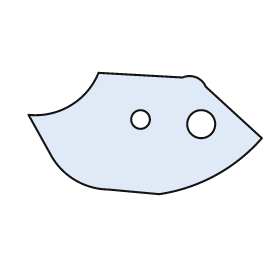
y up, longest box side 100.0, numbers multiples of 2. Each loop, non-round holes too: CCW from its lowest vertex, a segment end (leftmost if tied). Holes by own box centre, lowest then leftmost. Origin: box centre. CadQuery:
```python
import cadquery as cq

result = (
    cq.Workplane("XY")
    .moveTo(6.0, -26.0)
    .threePointArc((30.0, -18.0), (50.0, -2.0))
    .lineTo(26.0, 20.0)
    .threePointArc((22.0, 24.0), (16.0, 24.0))
    .lineTo(-20.0, 26.0)
    .threePointArc((-32.0, 12.0), (-50.0, 8.0))
    .lineTo(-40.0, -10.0)
    .threePointArc((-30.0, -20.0), (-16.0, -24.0))
    .close()
    .moveTo(24.0, 4.0)
    .circle(6.0)
    .moveTo(-2.0, 6.0)
    .circle(4.0)
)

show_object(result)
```